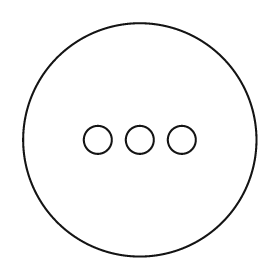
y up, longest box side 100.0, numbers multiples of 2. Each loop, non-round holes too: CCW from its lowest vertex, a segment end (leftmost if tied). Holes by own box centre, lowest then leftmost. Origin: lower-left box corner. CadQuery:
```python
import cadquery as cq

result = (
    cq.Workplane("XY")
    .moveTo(50.0, 50.0)
    .circle(50.0)
    .moveTo(32.0, 50.0)
    .circle(6.0)
    .moveTo(50.0, 50.0)
    .circle(6.0)
    .moveTo(68.0, 50.0)
    .circle(6.0)
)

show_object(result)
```